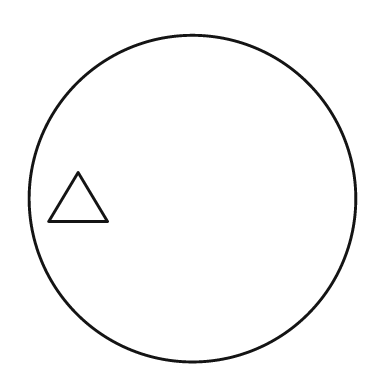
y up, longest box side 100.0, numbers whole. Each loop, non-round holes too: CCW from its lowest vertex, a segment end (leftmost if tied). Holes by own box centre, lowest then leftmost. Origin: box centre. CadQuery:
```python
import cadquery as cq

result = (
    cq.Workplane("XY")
    .moveTo(0.0, 0.0)
    .circle(50.0)
    .moveTo(-44.0, -7.0)
    .lineTo(-26.0, -7.0)
    .lineTo(-35.0, 8.0)
    .close()
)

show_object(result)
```